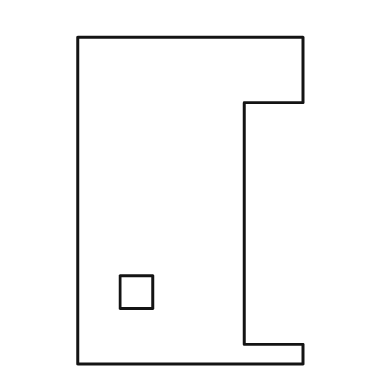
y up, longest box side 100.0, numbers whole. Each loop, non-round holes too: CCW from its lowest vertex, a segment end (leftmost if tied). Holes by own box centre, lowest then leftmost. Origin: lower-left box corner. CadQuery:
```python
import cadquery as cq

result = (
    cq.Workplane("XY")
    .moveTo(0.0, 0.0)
    .lineTo(69.0, 0.0)
    .lineTo(69.0, 6.0)
    .lineTo(51.0, 6.0)
    .lineTo(51.0, 80.0)
    .lineTo(69.0, 80.0)
    .lineTo(69.0, 100.0)
    .lineTo(0.0, 100.0)
    .close()
    .moveTo(13.0, 17.0)
    .lineTo(23.0, 17.0)
    .lineTo(23.0, 27.0)
    .lineTo(13.0, 27.0)
    .close()
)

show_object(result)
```